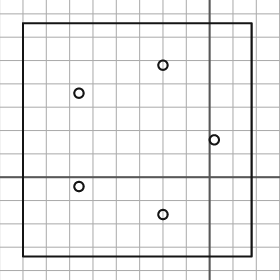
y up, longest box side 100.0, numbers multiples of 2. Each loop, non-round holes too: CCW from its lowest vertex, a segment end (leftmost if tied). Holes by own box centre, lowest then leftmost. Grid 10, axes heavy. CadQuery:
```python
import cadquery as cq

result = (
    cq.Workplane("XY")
    .moveTo(-80.0, -34.0)
    .lineTo(18.0, -34.0)
    .lineTo(18.0, 66.0)
    .lineTo(-80.0, 66.0)
    .close()
    .moveTo(-20.0, -16.0)
    .circle(2.0)
    .moveTo(-56.0, -4.0)
    .circle(2.0)
    .moveTo(2.0, 16.0)
    .circle(2.0)
    .moveTo(-56.0, 36.0)
    .circle(2.0)
    .moveTo(-20.0, 48.0)
    .circle(2.0)
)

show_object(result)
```